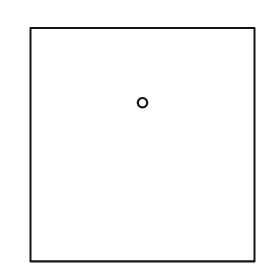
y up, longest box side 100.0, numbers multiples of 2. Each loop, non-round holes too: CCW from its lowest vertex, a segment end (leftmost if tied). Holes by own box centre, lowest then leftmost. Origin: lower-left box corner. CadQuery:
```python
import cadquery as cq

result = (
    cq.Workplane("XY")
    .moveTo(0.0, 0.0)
    .lineTo(96.0, 0.0)
    .lineTo(96.0, 100.0)
    .lineTo(0.0, 100.0)
    .close()
    .moveTo(48.0, 68.0)
    .circle(2.0)
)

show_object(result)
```